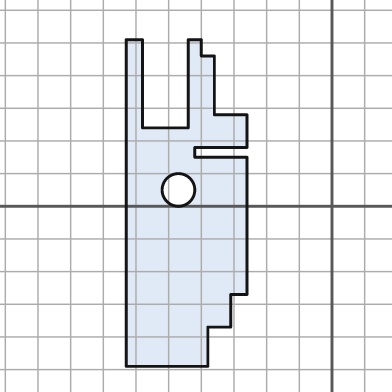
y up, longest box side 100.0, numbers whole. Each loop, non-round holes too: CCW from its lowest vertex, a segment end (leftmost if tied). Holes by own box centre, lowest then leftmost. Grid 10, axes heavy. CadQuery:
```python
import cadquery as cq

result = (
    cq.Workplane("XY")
    .moveTo(-63.0, -49.0)
    .lineTo(-38.0, -49.0)
    .lineTo(-38.0, -37.0)
    .lineTo(-31.0, -37.0)
    .lineTo(-31.0, -27.0)
    .lineTo(-26.0, -27.0)
    .lineTo(-26.0, 15.0)
    .lineTo(-42.0, 15.0)
    .lineTo(-42.0, 18.0)
    .lineTo(-26.0, 18.0)
    .lineTo(-26.0, 28.0)
    .lineTo(-36.0, 28.0)
    .lineTo(-36.0, 46.0)
    .lineTo(-40.0, 46.0)
    .lineTo(-40.0, 51.0)
    .lineTo(-44.0, 51.0)
    .lineTo(-44.0, 24.0)
    .lineTo(-58.0, 24.0)
    .lineTo(-58.0, 51.0)
    .lineTo(-63.0, 51.0)
    .close()
    .moveTo(-47.0, 5.0)
    .circle(5.0)
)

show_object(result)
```